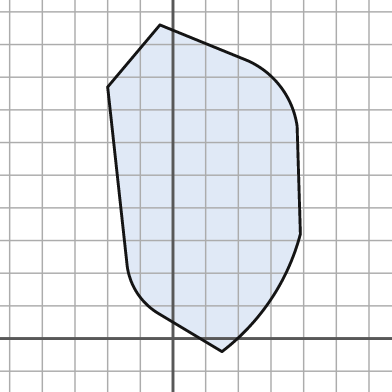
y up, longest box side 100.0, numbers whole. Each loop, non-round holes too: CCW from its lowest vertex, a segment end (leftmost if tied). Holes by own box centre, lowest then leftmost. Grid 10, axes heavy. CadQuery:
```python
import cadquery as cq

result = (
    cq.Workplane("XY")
    .moveTo(15.0, -4.0)
    .threePointArc((30.0, 12.0), (39.0, 32.0))
    .lineTo(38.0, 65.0)
    .threePointArc((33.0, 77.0), (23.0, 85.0))
    .lineTo(-4.0, 96.0)
    .lineTo(-20.0, 77.0)
    .lineTo(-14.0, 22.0)
    .threePointArc((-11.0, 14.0), (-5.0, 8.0))
    .close()
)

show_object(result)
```